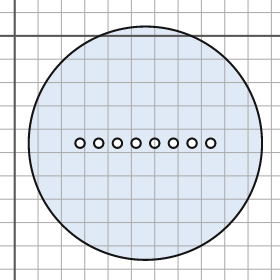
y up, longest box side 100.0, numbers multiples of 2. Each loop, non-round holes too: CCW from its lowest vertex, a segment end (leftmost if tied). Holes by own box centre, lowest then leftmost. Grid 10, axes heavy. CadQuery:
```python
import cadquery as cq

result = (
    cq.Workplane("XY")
    .moveTo(56.0, -46.0)
    .circle(50.0)
    .moveTo(28.0, -46.0)
    .circle(2.0)
    .moveTo(36.0, -46.0)
    .circle(2.0)
    .moveTo(44.0, -46.0)
    .circle(2.0)
    .moveTo(52.0, -46.0)
    .circle(2.0)
    .moveTo(60.0, -46.0)
    .circle(2.0)
    .moveTo(68.0, -46.0)
    .circle(2.0)
    .moveTo(76.0, -46.0)
    .circle(2.0)
    .moveTo(84.0, -46.0)
    .circle(2.0)
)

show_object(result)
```